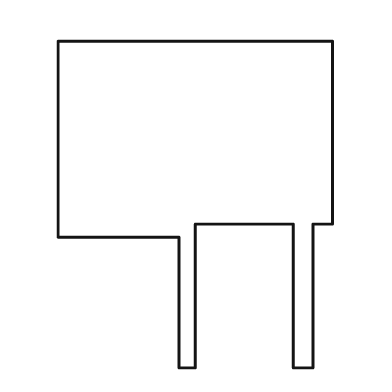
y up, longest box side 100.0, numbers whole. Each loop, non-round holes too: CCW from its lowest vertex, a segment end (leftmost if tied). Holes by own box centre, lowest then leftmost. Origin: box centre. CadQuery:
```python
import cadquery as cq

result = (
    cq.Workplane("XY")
    .moveTo(-5.0, -50.0)
    .lineTo(0.0, -50.0)
    .lineTo(0.0, -6.0)
    .lineTo(30.0, -6.0)
    .lineTo(30.0, -50.0)
    .lineTo(36.0, -50.0)
    .lineTo(36.0, -6.0)
    .lineTo(42.0, -6.0)
    .lineTo(42.0, 50.0)
    .lineTo(-42.0, 50.0)
    .lineTo(-42.0, -10.0)
    .lineTo(-5.0, -10.0)
    .close()
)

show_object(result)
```